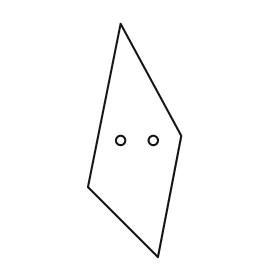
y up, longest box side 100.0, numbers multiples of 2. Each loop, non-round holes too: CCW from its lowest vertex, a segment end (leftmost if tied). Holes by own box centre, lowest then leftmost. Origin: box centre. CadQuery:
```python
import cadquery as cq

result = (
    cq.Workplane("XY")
    .moveTo(10.0, -50.0)
    .lineTo(20.0, 2.0)
    .lineTo(-6.0, 50.0)
    .lineTo(-20.0, -20.0)
    .close()
    .moveTo(-6.0, 0.0)
    .circle(2.0)
    .moveTo(8.0, 0.0)
    .circle(2.0)
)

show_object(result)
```